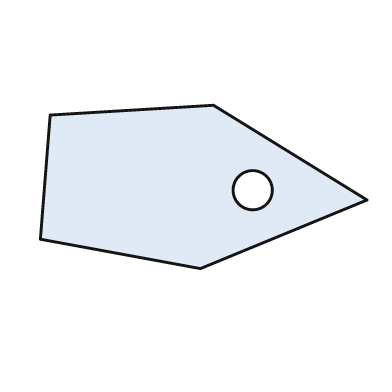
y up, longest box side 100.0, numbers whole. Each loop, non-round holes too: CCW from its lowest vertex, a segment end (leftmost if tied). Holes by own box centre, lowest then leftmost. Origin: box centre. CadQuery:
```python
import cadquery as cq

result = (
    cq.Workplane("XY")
    .moveTo(-1.0, -25.0)
    .lineTo(50.0, -4.0)
    .lineTo(3.0, 25.0)
    .lineTo(-47.0, 22.0)
    .lineTo(-50.0, -16.0)
    .close()
    .moveTo(15.0, -1.0)
    .circle(6.0)
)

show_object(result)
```